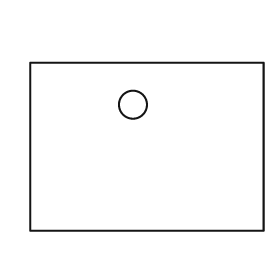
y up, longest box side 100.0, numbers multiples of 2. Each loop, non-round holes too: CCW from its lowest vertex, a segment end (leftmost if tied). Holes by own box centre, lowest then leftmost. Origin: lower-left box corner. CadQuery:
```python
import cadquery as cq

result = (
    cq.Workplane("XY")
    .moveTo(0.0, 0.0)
    .lineTo(100.0, 0.0)
    .lineTo(100.0, 72.0)
    .lineTo(0.0, 72.0)
    .close()
    .moveTo(44.0, 54.0)
    .circle(6.0)
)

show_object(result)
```